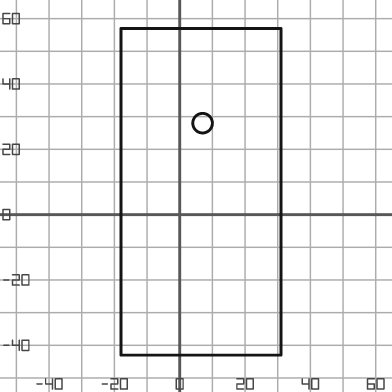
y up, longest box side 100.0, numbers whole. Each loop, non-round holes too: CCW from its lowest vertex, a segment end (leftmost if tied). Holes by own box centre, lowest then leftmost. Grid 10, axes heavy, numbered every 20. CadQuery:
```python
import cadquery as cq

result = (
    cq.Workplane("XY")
    .moveTo(-18.0, -43.0)
    .lineTo(31.0, -43.0)
    .lineTo(31.0, 57.0)
    .lineTo(-18.0, 57.0)
    .close()
    .moveTo(7.0, 28.0)
    .circle(3.0)
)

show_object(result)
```